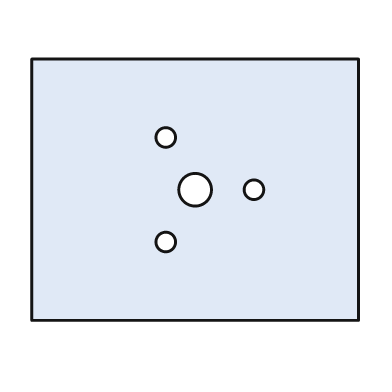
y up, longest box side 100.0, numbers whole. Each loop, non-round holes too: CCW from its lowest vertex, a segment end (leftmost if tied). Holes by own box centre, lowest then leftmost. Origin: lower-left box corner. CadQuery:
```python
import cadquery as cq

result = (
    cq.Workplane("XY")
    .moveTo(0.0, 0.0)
    .lineTo(100.0, 0.0)
    .lineTo(100.0, 80.0)
    .lineTo(0.0, 80.0)
    .close()
    .moveTo(41.0, 24.0)
    .circle(3.0)
    .moveTo(50.0, 40.0)
    .circle(5.0)
    .moveTo(68.0, 40.0)
    .circle(3.0)
    .moveTo(41.0, 56.0)
    .circle(3.0)
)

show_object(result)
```